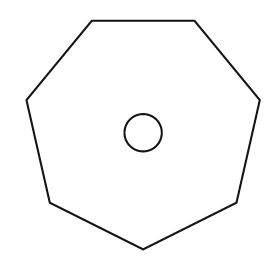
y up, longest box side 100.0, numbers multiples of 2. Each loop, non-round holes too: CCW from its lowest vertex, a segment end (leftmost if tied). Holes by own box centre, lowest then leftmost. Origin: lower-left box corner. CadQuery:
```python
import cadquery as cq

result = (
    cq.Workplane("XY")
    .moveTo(50.0, 0.0)
    .lineTo(90.0, 20.0)
    .lineTo(100.0, 64.0)
    .lineTo(72.0, 98.0)
    .lineTo(28.0, 98.0)
    .lineTo(0.0, 64.0)
    .lineTo(10.0, 20.0)
    .close()
    .moveTo(50.0, 50.0)
    .circle(8.0)
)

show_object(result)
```